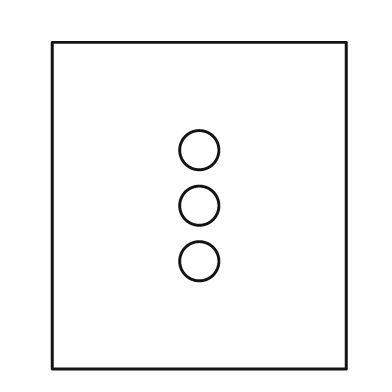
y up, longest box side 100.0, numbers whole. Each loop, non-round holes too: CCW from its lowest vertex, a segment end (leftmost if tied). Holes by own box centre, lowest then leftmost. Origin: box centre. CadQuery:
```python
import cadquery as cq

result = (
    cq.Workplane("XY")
    .moveTo(-45.0, -50.0)
    .lineTo(45.0, -50.0)
    .lineTo(45.0, 50.0)
    .lineTo(-45.0, 50.0)
    .close()
    .moveTo(0.0, -17.0)
    .circle(6.0)
    .moveTo(0.0, 0.0)
    .circle(6.0)
    .moveTo(0.0, 17.0)
    .circle(6.0)
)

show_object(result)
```